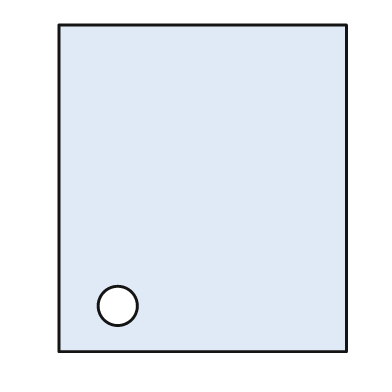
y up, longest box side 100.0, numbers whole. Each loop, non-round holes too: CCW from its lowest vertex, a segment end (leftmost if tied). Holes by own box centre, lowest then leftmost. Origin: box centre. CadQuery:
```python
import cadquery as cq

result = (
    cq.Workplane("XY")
    .moveTo(-44.0, -50.0)
    .lineTo(44.0, -50.0)
    .lineTo(44.0, 50.0)
    .lineTo(-44.0, 50.0)
    .close()
    .moveTo(-26.0, -36.0)
    .circle(6.0)
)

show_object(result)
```